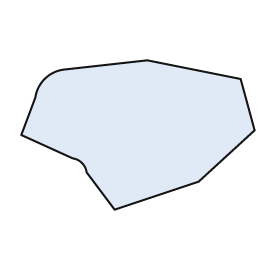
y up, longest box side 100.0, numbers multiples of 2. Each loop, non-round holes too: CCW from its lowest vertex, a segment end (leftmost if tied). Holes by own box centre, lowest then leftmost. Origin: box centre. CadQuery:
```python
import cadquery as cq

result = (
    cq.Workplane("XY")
    .moveTo(-10.0, -32.0)
    .lineTo(26.0, -20.0)
    .lineTo(50.0, 2.0)
    .lineTo(44.0, 24.0)
    .lineTo(4.0, 32.0)
    .lineTo(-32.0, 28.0)
    .threePointArc((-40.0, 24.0), (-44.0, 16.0))
    .lineTo(-50.0, 0.0)
    .lineTo(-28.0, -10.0)
    .threePointArc((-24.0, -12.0), (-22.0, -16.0))
    .close()
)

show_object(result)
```